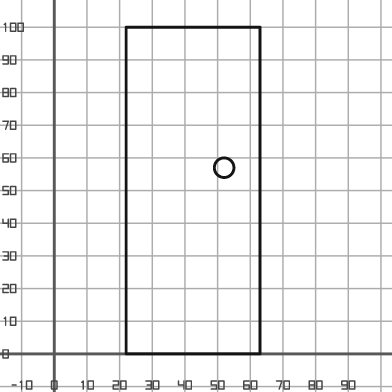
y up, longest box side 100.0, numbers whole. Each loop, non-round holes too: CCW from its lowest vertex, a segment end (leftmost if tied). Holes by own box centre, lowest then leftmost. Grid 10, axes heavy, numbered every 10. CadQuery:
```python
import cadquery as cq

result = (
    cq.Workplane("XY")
    .moveTo(22.0, 0.0)
    .lineTo(63.0, 0.0)
    .lineTo(63.0, 100.0)
    .lineTo(22.0, 100.0)
    .close()
    .moveTo(52.0, 57.0)
    .circle(3.0)
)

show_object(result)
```